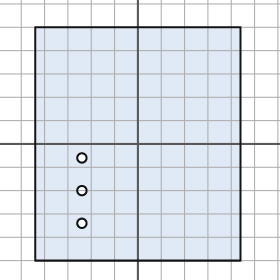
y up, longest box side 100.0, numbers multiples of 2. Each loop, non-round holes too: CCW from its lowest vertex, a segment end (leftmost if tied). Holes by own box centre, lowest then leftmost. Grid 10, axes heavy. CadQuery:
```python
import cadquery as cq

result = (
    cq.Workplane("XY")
    .moveTo(-44.0, -50.0)
    .lineTo(44.0, -50.0)
    .lineTo(44.0, 50.0)
    .lineTo(-44.0, 50.0)
    .close()
    .moveTo(-24.0, -34.0)
    .circle(2.0)
    .moveTo(-24.0, -20.0)
    .circle(2.0)
    .moveTo(-24.0, -6.0)
    .circle(2.0)
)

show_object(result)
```